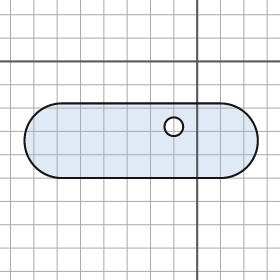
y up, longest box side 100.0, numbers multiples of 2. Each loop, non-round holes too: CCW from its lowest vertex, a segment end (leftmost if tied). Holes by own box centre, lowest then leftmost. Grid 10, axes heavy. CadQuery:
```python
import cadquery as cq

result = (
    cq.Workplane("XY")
    .moveTo(-58.0, -50.0)
    .lineTo(10.0, -50.0)
    .threePointArc((26.0, -34.0), (10.0, -18.0))
    .lineTo(-58.0, -18.0)
    .threePointArc((-74.0, -34.0), (-58.0, -50.0))
    .close()
    .moveTo(-10.0, -28.0)
    .circle(4.0)
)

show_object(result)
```